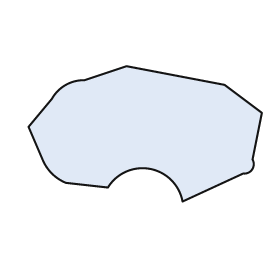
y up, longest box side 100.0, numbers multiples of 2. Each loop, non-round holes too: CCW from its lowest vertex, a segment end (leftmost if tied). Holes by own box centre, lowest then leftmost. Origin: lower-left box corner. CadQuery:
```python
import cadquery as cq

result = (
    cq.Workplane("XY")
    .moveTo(66.0, 0.0)
    .lineTo(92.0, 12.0)
    .threePointArc((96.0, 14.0), (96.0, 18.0))
    .lineTo(100.0, 38.0)
    .lineTo(84.0, 50.0)
    .lineTo(42.0, 58.0)
    .lineTo(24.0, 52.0)
    .threePointArc((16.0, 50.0), (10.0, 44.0))
    .lineTo(0.0, 32.0)
    .lineTo(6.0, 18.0)
    .threePointArc((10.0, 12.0), (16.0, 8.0))
    .lineTo(34.0, 6.0)
    .threePointArc((52.0, 14.0), (66.0, 0.0))
    .close()
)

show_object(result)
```